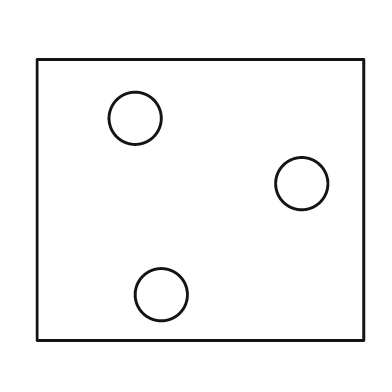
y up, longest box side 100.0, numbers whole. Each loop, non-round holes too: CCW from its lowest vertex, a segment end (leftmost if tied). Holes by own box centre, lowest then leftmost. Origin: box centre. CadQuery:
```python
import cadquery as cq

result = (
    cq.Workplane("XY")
    .moveTo(-50.0, -43.0)
    .lineTo(50.0, -43.0)
    .lineTo(50.0, 43.0)
    .lineTo(-50.0, 43.0)
    .close()
    .moveTo(-12.0, -29.0)
    .circle(8.0)
    .moveTo(31.0, 5.0)
    .circle(8.0)
    .moveTo(-20.0, 25.0)
    .circle(8.0)
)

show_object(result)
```